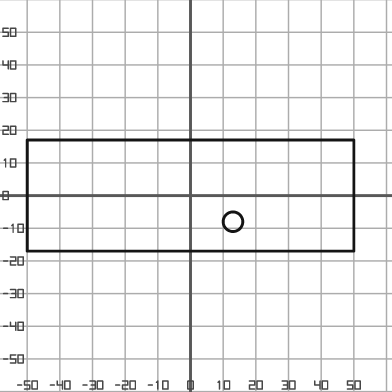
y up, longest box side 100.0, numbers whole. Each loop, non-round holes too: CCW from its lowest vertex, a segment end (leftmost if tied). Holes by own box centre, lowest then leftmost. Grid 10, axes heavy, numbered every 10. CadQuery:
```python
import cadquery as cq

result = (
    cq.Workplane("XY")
    .moveTo(-50.0, -17.0)
    .lineTo(50.0, -17.0)
    .lineTo(50.0, 17.0)
    .lineTo(-50.0, 17.0)
    .close()
    .moveTo(13.0, -8.0)
    .circle(3.0)
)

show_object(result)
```